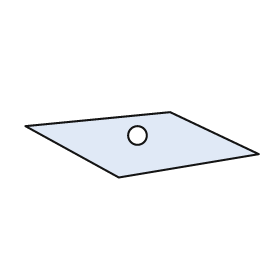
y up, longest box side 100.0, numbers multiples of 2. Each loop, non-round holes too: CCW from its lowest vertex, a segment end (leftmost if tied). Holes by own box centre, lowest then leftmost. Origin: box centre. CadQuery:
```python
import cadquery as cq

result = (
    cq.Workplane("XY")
    .moveTo(-10.0, -14.0)
    .lineTo(50.0, -4.0)
    .lineTo(12.0, 14.0)
    .lineTo(-50.0, 8.0)
    .close()
    .moveTo(-2.0, 4.0)
    .circle(4.0)
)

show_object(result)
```